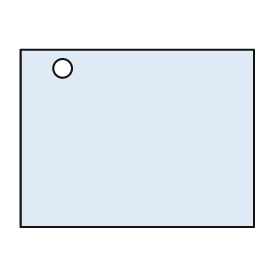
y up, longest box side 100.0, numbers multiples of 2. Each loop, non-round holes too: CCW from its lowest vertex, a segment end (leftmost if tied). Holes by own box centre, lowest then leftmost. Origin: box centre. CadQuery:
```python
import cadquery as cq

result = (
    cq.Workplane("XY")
    .moveTo(-50.0, -38.0)
    .lineTo(50.0, -38.0)
    .lineTo(50.0, 38.0)
    .lineTo(-50.0, 38.0)
    .close()
    .moveTo(-32.0, 30.0)
    .circle(4.0)
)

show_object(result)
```